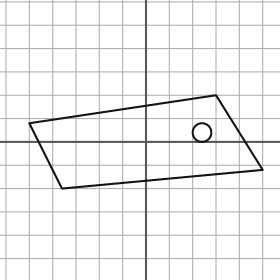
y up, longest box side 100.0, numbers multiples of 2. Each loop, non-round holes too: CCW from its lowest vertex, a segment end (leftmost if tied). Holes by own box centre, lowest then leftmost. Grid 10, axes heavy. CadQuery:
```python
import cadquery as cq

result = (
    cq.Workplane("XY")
    .moveTo(-36.0, -20.0)
    .lineTo(50.0, -12.0)
    .lineTo(30.0, 20.0)
    .lineTo(-50.0, 8.0)
    .close()
    .moveTo(24.0, 4.0)
    .circle(4.0)
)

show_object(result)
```